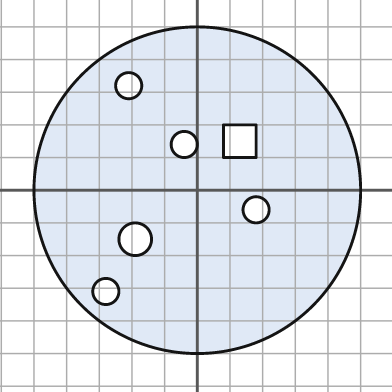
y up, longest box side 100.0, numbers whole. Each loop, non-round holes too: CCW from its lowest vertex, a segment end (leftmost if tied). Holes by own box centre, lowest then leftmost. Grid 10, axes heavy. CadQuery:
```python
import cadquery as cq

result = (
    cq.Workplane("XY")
    .moveTo(0.0, 0.0)
    .circle(50.0)
    .moveTo(-28.0, -31.0)
    .circle(4.0)
    .moveTo(-19.0, -15.0)
    .circle(5.0)
    .moveTo(18.0, -6.0)
    .circle(4.0)
    .moveTo(-4.0, 14.0)
    .circle(4.0)
    .moveTo(8.0, 10.0)
    .lineTo(18.0, 10.0)
    .lineTo(18.0, 20.0)
    .lineTo(8.0, 20.0)
    .close()
    .moveTo(-21.0, 32.0)
    .circle(4.0)
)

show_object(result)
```